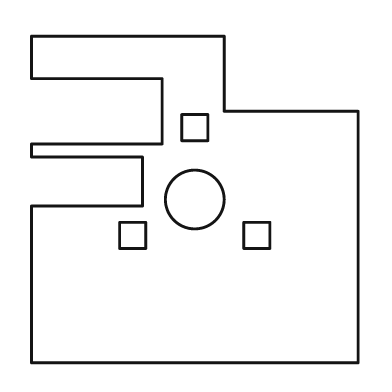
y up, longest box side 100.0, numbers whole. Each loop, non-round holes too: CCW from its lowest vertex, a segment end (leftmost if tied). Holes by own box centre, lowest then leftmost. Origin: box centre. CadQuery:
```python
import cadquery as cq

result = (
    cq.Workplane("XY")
    .moveTo(-50.0, -50.0)
    .lineTo(50.0, -50.0)
    .lineTo(50.0, 27.0)
    .lineTo(9.0, 27.0)
    .lineTo(9.0, 50.0)
    .lineTo(-50.0, 50.0)
    .lineTo(-50.0, 37.0)
    .lineTo(-10.0, 37.0)
    .lineTo(-10.0, 17.0)
    .lineTo(-50.0, 17.0)
    .lineTo(-50.0, 13.0)
    .lineTo(-16.0, 13.0)
    .lineTo(-16.0, -2.0)
    .lineTo(-50.0, -2.0)
    .close()
    .moveTo(-23.0, -15.0)
    .lineTo(-15.0, -15.0)
    .lineTo(-15.0, -7.0)
    .lineTo(-23.0, -7.0)
    .close()
    .moveTo(15.0, -15.0)
    .lineTo(23.0, -15.0)
    .lineTo(23.0, -7.0)
    .lineTo(15.0, -7.0)
    .close()
    .moveTo(0.0, 0.0)
    .circle(9.0)
    .moveTo(-4.0, 18.0)
    .lineTo(4.0, 18.0)
    .lineTo(4.0, 26.0)
    .lineTo(-4.0, 26.0)
    .close()
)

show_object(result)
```